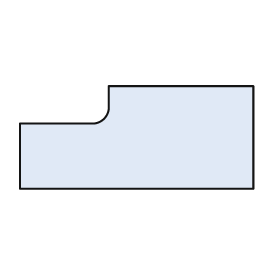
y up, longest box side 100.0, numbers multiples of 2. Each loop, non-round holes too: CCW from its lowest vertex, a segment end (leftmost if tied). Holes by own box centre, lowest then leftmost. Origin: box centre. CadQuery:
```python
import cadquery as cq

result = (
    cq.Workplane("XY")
    .moveTo(-50.0, -22.0)
    .lineTo(50.0, -22.0)
    .lineTo(50.0, 22.0)
    .lineTo(-12.0, 22.0)
    .lineTo(-12.0, 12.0)
    .threePointArc((-14.0, 8.0), (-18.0, 6.0))
    .lineTo(-50.0, 6.0)
    .close()
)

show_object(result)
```